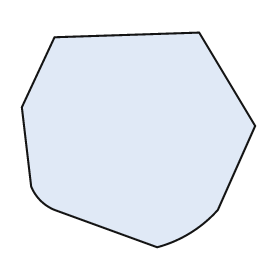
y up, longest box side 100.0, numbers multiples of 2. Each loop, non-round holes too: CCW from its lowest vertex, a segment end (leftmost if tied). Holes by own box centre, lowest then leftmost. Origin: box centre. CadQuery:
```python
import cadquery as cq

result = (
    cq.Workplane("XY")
    .moveTo(8.0, -46.0)
    .threePointArc((22.0, -40.0), (34.0, -30.0))
    .lineTo(50.0, 6.0)
    .lineTo(26.0, 46.0)
    .lineTo(-36.0, 44.0)
    .lineTo(-50.0, 14.0)
    .lineTo(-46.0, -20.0)
    .threePointArc((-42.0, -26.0), (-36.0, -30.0))
    .close()
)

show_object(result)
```